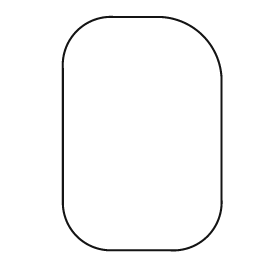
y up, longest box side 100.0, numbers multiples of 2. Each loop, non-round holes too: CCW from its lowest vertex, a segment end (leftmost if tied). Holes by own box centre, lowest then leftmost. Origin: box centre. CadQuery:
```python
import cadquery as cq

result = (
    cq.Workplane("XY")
    .moveTo(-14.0, -50.0)
    .lineTo(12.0, -50.0)
    .threePointArc((28.0, -44.0), (34.0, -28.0))
    .lineTo(34.0, 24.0)
    .threePointArc((26.0, 42.0), (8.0, 50.0))
    .lineTo(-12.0, 50.0)
    .threePointArc((-28.0, 44.0), (-34.0, 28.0))
    .lineTo(-34.0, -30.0)
    .threePointArc((-28.0, -44.0), (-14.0, -50.0))
    .close()
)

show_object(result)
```